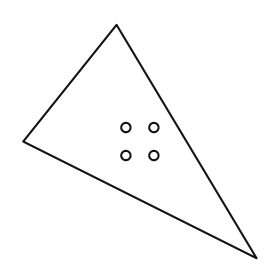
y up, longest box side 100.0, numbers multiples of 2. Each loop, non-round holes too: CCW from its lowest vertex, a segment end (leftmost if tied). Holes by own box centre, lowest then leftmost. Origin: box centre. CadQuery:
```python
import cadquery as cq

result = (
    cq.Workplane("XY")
    .moveTo(50.0, -50.0)
    .lineTo(-10.0, 50.0)
    .lineTo(-50.0, 0.0)
    .close()
    .moveTo(-6.0, -6.0)
    .circle(2.0)
    .moveTo(6.0, -6.0)
    .circle(2.0)
    .moveTo(-6.0, 6.0)
    .circle(2.0)
    .moveTo(6.0, 6.0)
    .circle(2.0)
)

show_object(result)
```